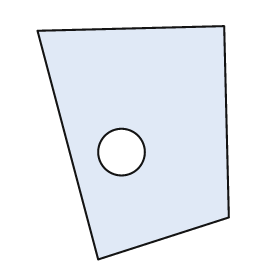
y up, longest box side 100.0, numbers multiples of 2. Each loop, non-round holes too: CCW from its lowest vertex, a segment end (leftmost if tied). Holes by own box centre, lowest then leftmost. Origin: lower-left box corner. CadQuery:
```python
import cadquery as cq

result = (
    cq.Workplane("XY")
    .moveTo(26.0, 0.0)
    .lineTo(82.0, 18.0)
    .lineTo(80.0, 100.0)
    .lineTo(0.0, 98.0)
    .close()
    .moveTo(36.0, 46.0)
    .circle(10.0)
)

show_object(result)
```